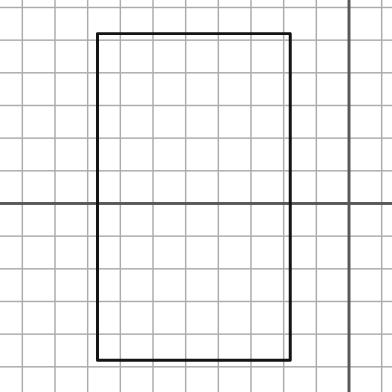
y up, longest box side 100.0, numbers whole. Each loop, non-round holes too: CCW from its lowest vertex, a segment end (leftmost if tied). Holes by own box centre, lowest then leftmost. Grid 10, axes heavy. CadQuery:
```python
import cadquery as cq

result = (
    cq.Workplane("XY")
    .moveTo(-77.0, -48.0)
    .lineTo(-18.0, -48.0)
    .lineTo(-18.0, 52.0)
    .lineTo(-77.0, 52.0)
    .close()
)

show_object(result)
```